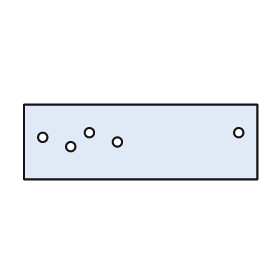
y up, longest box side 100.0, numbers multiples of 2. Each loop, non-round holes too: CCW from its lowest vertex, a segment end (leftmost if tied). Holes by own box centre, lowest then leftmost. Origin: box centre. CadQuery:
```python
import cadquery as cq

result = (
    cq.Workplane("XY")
    .moveTo(-50.0, -16.0)
    .lineTo(50.0, -16.0)
    .lineTo(50.0, 16.0)
    .lineTo(-50.0, 16.0)
    .close()
    .moveTo(-30.0, -2.0)
    .circle(2.0)
    .moveTo(-10.0, 0.0)
    .circle(2.0)
    .moveTo(-42.0, 2.0)
    .circle(2.0)
    .moveTo(-22.0, 4.0)
    .circle(2.0)
    .moveTo(42.0, 4.0)
    .circle(2.0)
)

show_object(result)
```